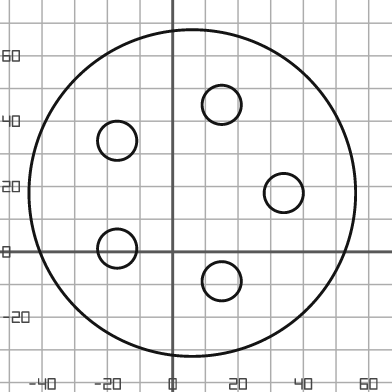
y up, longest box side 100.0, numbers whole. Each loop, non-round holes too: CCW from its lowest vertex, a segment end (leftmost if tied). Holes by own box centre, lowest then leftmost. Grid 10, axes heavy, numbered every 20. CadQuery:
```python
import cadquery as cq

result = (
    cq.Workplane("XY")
    .moveTo(6.0, 18.0)
    .circle(50.0)
    .moveTo(15.0, -9.0)
    .circle(6.0)
    .moveTo(-17.0, 1.0)
    .circle(6.0)
    .moveTo(34.0, 18.0)
    .circle(6.0)
    .moveTo(-17.0, 34.0)
    .circle(6.0)
    .moveTo(15.0, 45.0)
    .circle(6.0)
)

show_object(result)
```